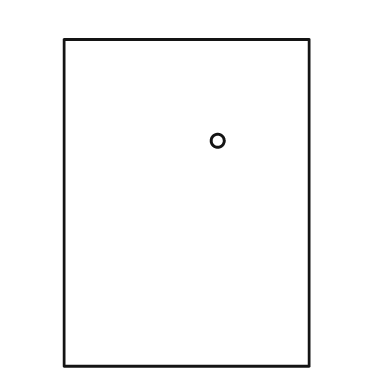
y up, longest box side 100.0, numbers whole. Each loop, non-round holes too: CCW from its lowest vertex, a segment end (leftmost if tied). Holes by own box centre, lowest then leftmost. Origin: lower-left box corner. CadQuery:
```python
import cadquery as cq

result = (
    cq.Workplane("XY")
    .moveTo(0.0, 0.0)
    .lineTo(75.0, 0.0)
    .lineTo(75.0, 100.0)
    .lineTo(0.0, 100.0)
    .close()
    .moveTo(47.0, 69.0)
    .circle(2.0)
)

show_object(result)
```